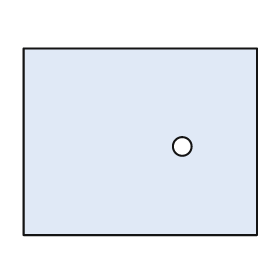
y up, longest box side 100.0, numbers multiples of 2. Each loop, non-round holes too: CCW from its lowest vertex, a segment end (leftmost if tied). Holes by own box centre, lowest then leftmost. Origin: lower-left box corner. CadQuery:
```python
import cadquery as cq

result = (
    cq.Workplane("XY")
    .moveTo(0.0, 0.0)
    .lineTo(100.0, 0.0)
    .lineTo(100.0, 80.0)
    .lineTo(0.0, 80.0)
    .close()
    .moveTo(68.0, 38.0)
    .circle(4.0)
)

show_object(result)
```